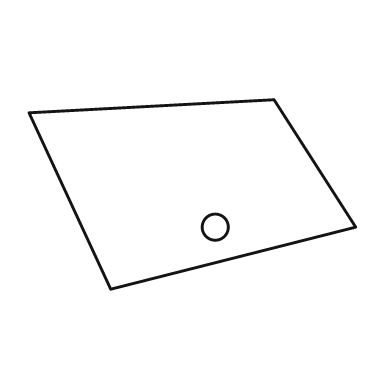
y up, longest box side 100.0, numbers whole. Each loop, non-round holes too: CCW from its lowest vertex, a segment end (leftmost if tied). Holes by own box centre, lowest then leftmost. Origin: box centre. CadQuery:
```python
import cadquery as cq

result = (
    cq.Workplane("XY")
    .moveTo(-25.0, -29.0)
    .lineTo(50.0, -10.0)
    .lineTo(25.0, 29.0)
    .lineTo(-50.0, 25.0)
    .close()
    .moveTo(7.0, -10.0)
    .circle(4.0)
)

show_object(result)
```